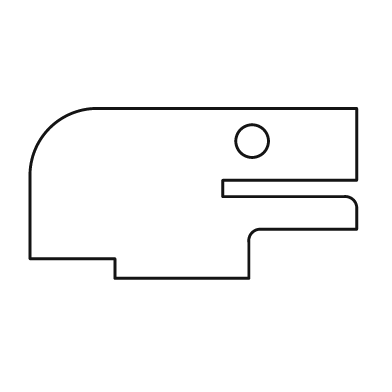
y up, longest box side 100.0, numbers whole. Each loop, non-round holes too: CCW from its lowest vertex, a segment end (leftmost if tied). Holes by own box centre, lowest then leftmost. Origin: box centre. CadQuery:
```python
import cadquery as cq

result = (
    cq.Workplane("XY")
    .moveTo(-24.0, -26.0)
    .lineTo(17.0, -26.0)
    .lineTo(17.0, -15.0)
    .threePointArc((18.0, -12.0), (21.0, -11.0))
    .lineTo(50.0, -11.0)
    .lineTo(50.0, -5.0)
    .threePointArc((49.0, -2.0), (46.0, -1.0))
    .lineTo(9.0, -1.0)
    .lineTo(9.0, 4.0)
    .lineTo(50.0, 4.0)
    .lineTo(50.0, 26.0)
    .lineTo(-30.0, 26.0)
    .threePointArc((-44.0, 20.0), (-50.0, 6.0))
    .lineTo(-50.0, -20.0)
    .lineTo(-24.0, -20.0)
    .close()
    .moveTo(18.0, 16.0)
    .circle(5.0)
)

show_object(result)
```